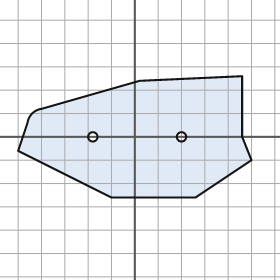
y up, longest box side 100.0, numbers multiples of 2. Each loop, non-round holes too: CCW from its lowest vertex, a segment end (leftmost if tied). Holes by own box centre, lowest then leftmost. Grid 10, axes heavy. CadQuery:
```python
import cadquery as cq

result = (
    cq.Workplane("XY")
    .moveTo(-10.0, -26.0)
    .lineTo(26.0, -26.0)
    .lineTo(50.0, -10.0)
    .lineTo(46.0, 0.0)
    .lineTo(46.0, 26.0)
    .lineTo(2.0, 24.0)
    .lineTo(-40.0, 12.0)
    .threePointArc((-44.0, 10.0), (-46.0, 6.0))
    .lineTo(-50.0, -6.0)
    .close()
    .moveTo(-18.0, 0.0)
    .circle(2.0)
    .moveTo(20.0, 0.0)
    .circle(2.0)
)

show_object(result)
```